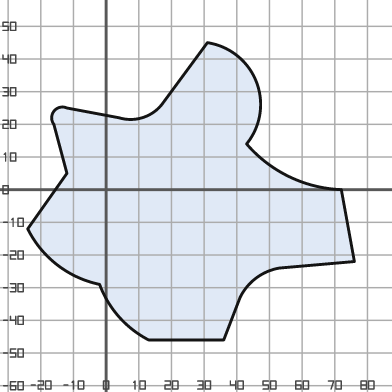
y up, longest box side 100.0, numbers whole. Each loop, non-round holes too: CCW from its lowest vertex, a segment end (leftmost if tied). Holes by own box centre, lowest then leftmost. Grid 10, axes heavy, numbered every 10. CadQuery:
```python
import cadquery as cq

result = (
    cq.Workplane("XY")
    .moveTo(13.0, -46.0)
    .lineTo(36.0, -46.0)
    .lineTo(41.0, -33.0)
    .threePointArc((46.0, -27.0), (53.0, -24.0))
    .lineTo(76.0, -22.0)
    .lineTo(72.0, 0.0)
    .threePointArc((56.0, 4.0), (43.0, 14.0))
    .threePointArc((46.0, 33.0), (31.0, 45.0))
    .lineTo(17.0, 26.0)
    .threePointArc((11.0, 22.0), (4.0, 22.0))
    .lineTo(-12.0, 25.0)
    .threePointArc((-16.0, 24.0), (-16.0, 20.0))
    .lineTo(-12.0, 5.0)
    .lineTo(-24.0, -12.0)
    .threePointArc((-15.0, -23.0), (-2.0, -29.0))
    .threePointArc((4.0, -39.0), (13.0, -46.0))
    .close()
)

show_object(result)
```